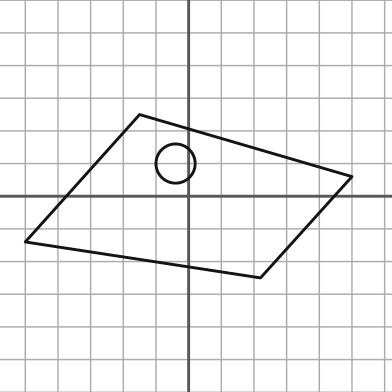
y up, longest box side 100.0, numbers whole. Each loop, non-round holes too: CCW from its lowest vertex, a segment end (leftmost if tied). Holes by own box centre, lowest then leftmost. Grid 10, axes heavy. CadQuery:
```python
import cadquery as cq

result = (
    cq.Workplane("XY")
    .moveTo(22.0, -25.0)
    .lineTo(50.0, 6.0)
    .lineTo(-15.0, 25.0)
    .lineTo(-50.0, -14.0)
    .close()
    .moveTo(-4.0, 10.0)
    .circle(6.0)
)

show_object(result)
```